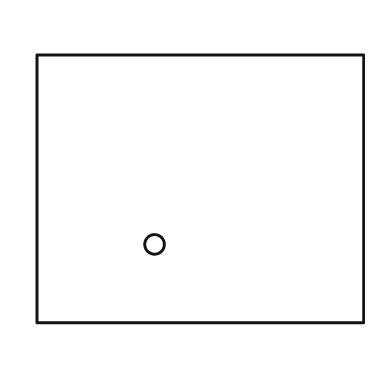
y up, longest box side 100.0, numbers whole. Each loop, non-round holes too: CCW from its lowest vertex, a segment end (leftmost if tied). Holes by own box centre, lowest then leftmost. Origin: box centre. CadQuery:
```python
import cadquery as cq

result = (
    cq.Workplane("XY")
    .moveTo(-50.0, -41.0)
    .lineTo(50.0, -41.0)
    .lineTo(50.0, 41.0)
    .lineTo(-50.0, 41.0)
    .close()
    .moveTo(-14.0, -17.0)
    .circle(3.0)
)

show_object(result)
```